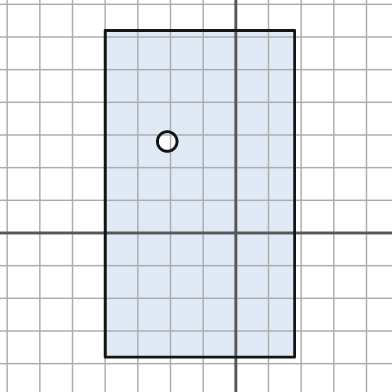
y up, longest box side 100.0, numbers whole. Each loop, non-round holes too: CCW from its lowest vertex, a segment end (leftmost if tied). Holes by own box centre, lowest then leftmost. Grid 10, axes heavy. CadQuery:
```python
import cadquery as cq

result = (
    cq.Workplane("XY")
    .moveTo(-40.0, -38.0)
    .lineTo(18.0, -38.0)
    .lineTo(18.0, 62.0)
    .lineTo(-40.0, 62.0)
    .close()
    .moveTo(-21.0, 28.0)
    .circle(3.0)
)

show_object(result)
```